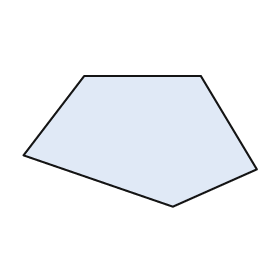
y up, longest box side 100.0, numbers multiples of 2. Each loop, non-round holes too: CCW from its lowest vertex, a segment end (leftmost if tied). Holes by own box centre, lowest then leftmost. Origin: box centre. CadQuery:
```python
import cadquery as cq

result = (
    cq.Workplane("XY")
    .moveTo(14.0, -28.0)
    .lineTo(50.0, -12.0)
    .lineTo(26.0, 28.0)
    .lineTo(-24.0, 28.0)
    .lineTo(-50.0, -6.0)
    .close()
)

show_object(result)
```